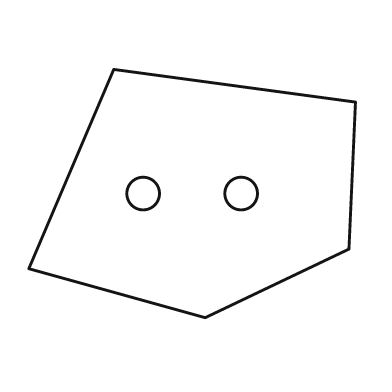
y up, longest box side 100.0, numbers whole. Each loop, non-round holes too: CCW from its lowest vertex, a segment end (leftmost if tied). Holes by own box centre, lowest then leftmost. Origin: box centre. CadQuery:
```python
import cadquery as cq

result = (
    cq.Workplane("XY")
    .moveTo(4.0, -38.0)
    .lineTo(48.0, -17.0)
    .lineTo(50.0, 28.0)
    .lineTo(-24.0, 38.0)
    .lineTo(-50.0, -23.0)
    .close()
    .moveTo(-15.0, 0.0)
    .circle(5.0)
    .moveTo(15.0, 0.0)
    .circle(5.0)
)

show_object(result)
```